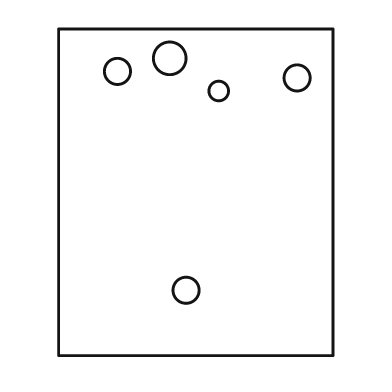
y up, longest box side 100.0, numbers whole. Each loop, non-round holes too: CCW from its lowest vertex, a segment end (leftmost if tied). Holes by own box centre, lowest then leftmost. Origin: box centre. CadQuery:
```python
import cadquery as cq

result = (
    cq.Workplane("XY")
    .moveTo(-42.0, -50.0)
    .lineTo(42.0, -50.0)
    .lineTo(42.0, 50.0)
    .lineTo(-42.0, 50.0)
    .close()
    .moveTo(-3.0, -30.0)
    .circle(4.0)
    .moveTo(7.0, 31.0)
    .circle(3.0)
    .moveTo(31.0, 35.0)
    .circle(4.0)
    .moveTo(-24.0, 37.0)
    .circle(4.0)
    .moveTo(-8.0, 41.0)
    .circle(5.0)
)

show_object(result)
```